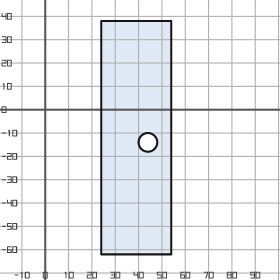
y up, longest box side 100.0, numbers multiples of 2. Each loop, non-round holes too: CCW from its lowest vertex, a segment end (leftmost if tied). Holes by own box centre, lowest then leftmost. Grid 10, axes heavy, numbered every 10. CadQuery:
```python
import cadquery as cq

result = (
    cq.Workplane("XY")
    .moveTo(24.0, -62.0)
    .lineTo(54.0, -62.0)
    .lineTo(54.0, 38.0)
    .lineTo(24.0, 38.0)
    .close()
    .moveTo(44.0, -14.0)
    .circle(4.0)
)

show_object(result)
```